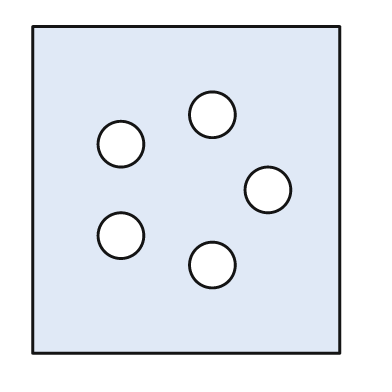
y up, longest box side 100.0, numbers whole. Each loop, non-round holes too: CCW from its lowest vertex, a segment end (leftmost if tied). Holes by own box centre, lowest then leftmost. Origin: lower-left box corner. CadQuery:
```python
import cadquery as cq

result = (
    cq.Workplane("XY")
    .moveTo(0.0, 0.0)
    .lineTo(94.0, 0.0)
    .lineTo(94.0, 100.0)
    .lineTo(0.0, 100.0)
    .close()
    .moveTo(55.0, 27.0)
    .circle(7.0)
    .moveTo(27.0, 36.0)
    .circle(7.0)
    .moveTo(72.0, 50.0)
    .circle(7.0)
    .moveTo(27.0, 64.0)
    .circle(7.0)
    .moveTo(55.0, 73.0)
    .circle(7.0)
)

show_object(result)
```